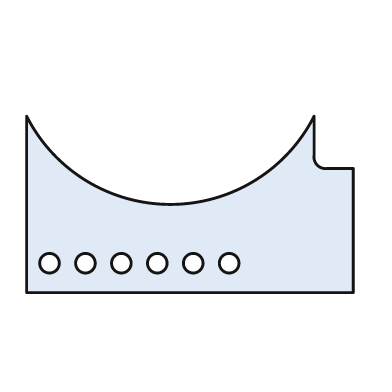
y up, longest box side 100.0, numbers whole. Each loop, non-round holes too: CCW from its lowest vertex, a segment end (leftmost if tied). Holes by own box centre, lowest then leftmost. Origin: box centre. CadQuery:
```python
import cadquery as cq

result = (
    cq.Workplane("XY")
    .moveTo(-50.0, -27.0)
    .lineTo(50.0, -27.0)
    .lineTo(50.0, 11.0)
    .lineTo(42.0, 11.0)
    .threePointArc((39.0, 12.0), (38.0, 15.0))
    .lineTo(38.0, 27.0)
    .threePointArc((-6.0, 0.0), (-50.0, 27.0))
    .close()
    .moveTo(-43.0, -18.0)
    .circle(3.0)
    .moveTo(-32.0, -18.0)
    .circle(3.0)
    .moveTo(-21.0, -18.0)
    .circle(3.0)
    .moveTo(-10.0, -18.0)
    .circle(3.0)
    .moveTo(1.0, -18.0)
    .circle(3.0)
    .moveTo(12.0, -18.0)
    .circle(3.0)
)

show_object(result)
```